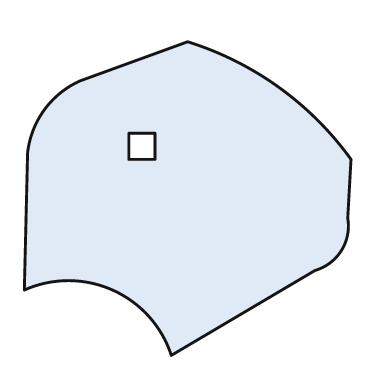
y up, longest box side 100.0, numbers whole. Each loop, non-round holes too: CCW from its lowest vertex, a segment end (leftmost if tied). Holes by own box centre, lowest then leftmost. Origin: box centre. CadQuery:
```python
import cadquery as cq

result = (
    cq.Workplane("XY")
    .moveTo(-5.0, -48.0)
    .lineTo(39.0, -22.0)
    .threePointArc((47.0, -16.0), (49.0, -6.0))
    .lineTo(50.0, 12.0)
    .threePointArc((28.0, 34.0), (0.0, 48.0))
    .lineTo(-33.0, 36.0)
    .threePointArc((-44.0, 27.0), (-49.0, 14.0))
    .lineTo(-50.0, -28.0)
    .threePointArc((-23.0, -28.0), (-5.0, -48.0))
    .close()
    .moveTo(-18.0, 12.0)
    .lineTo(-10.0, 12.0)
    .lineTo(-10.0, 20.0)
    .lineTo(-18.0, 20.0)
    .close()
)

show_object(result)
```